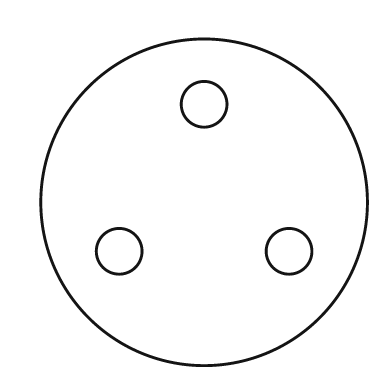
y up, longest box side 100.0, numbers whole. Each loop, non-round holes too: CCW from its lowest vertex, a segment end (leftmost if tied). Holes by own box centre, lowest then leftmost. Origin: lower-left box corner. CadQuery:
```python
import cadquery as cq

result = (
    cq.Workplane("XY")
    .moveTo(50.0, 50.0)
    .circle(50.0)
    .moveTo(24.0, 35.0)
    .circle(7.0)
    .moveTo(76.0, 35.0)
    .circle(7.0)
    .moveTo(50.0, 80.0)
    .circle(7.0)
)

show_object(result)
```